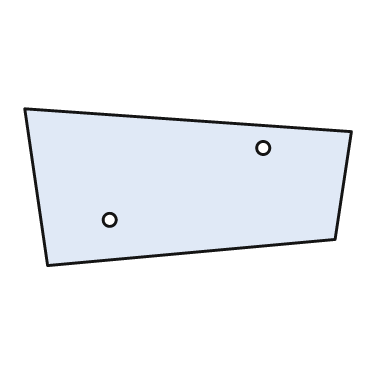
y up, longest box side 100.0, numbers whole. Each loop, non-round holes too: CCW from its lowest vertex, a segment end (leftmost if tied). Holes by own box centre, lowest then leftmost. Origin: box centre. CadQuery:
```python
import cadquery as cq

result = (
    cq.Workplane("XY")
    .moveTo(-43.0, -24.0)
    .lineTo(45.0, -16.0)
    .lineTo(50.0, 17.0)
    .lineTo(-50.0, 24.0)
    .close()
    .moveTo(-24.0, -10.0)
    .circle(2.0)
    .moveTo(23.0, 12.0)
    .circle(2.0)
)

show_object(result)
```